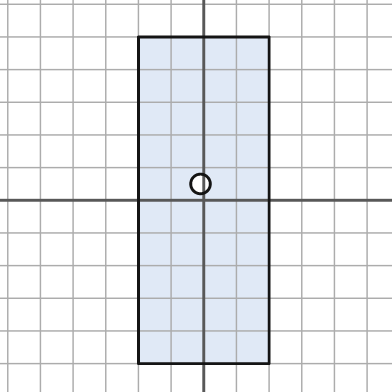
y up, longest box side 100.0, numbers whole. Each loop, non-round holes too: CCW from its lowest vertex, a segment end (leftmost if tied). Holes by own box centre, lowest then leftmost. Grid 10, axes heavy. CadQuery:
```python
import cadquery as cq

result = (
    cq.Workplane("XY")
    .moveTo(-20.0, -50.0)
    .lineTo(20.0, -50.0)
    .lineTo(20.0, 50.0)
    .lineTo(-20.0, 50.0)
    .close()
    .moveTo(-1.0, 5.0)
    .circle(3.0)
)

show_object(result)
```